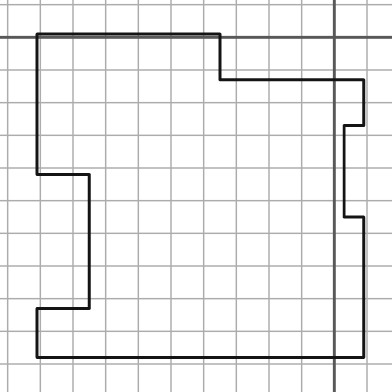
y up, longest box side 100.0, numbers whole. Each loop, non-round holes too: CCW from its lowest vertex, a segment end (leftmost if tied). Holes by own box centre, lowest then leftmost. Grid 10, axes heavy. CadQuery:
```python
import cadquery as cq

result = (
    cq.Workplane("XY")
    .moveTo(-91.0, -98.0)
    .lineTo(9.0, -98.0)
    .lineTo(9.0, -55.0)
    .lineTo(3.0, -55.0)
    .lineTo(3.0, -27.0)
    .lineTo(9.0, -27.0)
    .lineTo(9.0, -13.0)
    .lineTo(-35.0, -13.0)
    .lineTo(-35.0, 1.0)
    .lineTo(-91.0, 1.0)
    .lineTo(-91.0, -42.0)
    .lineTo(-75.0, -42.0)
    .lineTo(-75.0, -83.0)
    .lineTo(-91.0, -83.0)
    .close()
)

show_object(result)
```